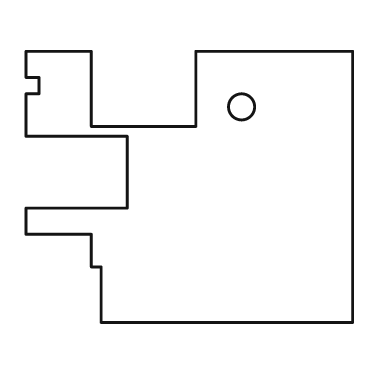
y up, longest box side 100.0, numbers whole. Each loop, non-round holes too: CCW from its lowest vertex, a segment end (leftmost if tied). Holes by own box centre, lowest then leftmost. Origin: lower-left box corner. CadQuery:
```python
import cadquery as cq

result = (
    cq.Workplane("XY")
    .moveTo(23.0, 0.0)
    .lineTo(100.0, 0.0)
    .lineTo(100.0, 83.0)
    .lineTo(52.0, 83.0)
    .lineTo(52.0, 60.0)
    .lineTo(20.0, 60.0)
    .lineTo(20.0, 83.0)
    .lineTo(0.0, 83.0)
    .lineTo(0.0, 75.0)
    .lineTo(4.0, 75.0)
    .lineTo(4.0, 70.0)
    .lineTo(0.0, 70.0)
    .lineTo(0.0, 57.0)
    .lineTo(31.0, 57.0)
    .lineTo(31.0, 35.0)
    .lineTo(0.0, 35.0)
    .lineTo(0.0, 27.0)
    .lineTo(20.0, 27.0)
    .lineTo(20.0, 17.0)
    .lineTo(23.0, 17.0)
    .close()
    .moveTo(66.0, 66.0)
    .circle(4.0)
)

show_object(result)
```